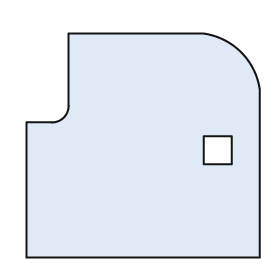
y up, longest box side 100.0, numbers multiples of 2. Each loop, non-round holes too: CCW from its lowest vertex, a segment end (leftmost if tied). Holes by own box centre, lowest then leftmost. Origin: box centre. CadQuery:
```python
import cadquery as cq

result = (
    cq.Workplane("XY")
    .moveTo(-50.0, -48.0)
    .lineTo(50.0, -48.0)
    .lineTo(50.0, 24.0)
    .threePointArc((42.0, 40.0), (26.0, 48.0))
    .lineTo(-32.0, 48.0)
    .lineTo(-32.0, 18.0)
    .threePointArc((-34.0, 12.0), (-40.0, 10.0))
    .lineTo(-50.0, 10.0)
    .close()
    .moveTo(26.0, -8.0)
    .lineTo(38.0, -8.0)
    .lineTo(38.0, 4.0)
    .lineTo(26.0, 4.0)
    .close()
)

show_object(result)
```